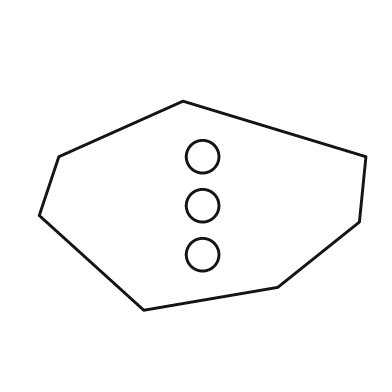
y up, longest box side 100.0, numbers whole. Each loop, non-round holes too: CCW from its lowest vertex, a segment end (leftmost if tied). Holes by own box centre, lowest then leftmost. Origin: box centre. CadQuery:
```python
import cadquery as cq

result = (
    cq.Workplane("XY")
    .moveTo(-18.0, -32.0)
    .lineTo(23.0, -25.0)
    .lineTo(48.0, -5.0)
    .lineTo(50.0, 15.0)
    .lineTo(-6.0, 32.0)
    .lineTo(-44.0, 15.0)
    .lineTo(-50.0, -3.0)
    .close()
    .moveTo(0.0, -15.0)
    .circle(5.0)
    .moveTo(0.0, 0.0)
    .circle(5.0)
    .moveTo(0.0, 15.0)
    .circle(5.0)
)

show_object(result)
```